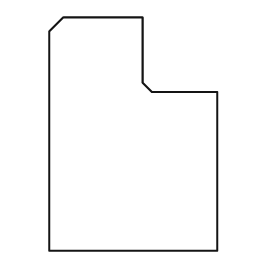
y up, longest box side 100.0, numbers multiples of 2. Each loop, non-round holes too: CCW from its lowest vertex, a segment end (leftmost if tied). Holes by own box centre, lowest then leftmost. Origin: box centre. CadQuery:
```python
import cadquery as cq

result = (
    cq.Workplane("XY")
    .moveTo(-36.0, -50.0)
    .lineTo(36.0, -50.0)
    .lineTo(36.0, 18.0)
    .lineTo(8.0, 18.0)
    .lineTo(4.0, 22.0)
    .lineTo(4.0, 50.0)
    .lineTo(-30.0, 50.0)
    .lineTo(-36.0, 44.0)
    .close()
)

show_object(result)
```